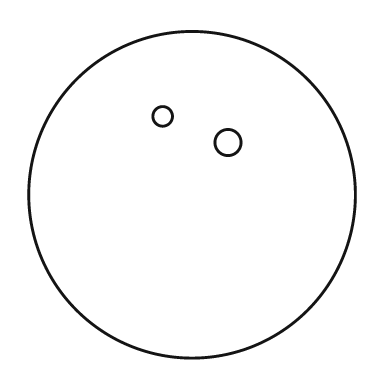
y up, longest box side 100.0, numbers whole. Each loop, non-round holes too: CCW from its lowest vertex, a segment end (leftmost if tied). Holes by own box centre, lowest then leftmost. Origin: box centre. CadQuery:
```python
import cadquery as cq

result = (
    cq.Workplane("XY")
    .moveTo(0.0, 0.0)
    .circle(50.0)
    .moveTo(11.0, 16.0)
    .circle(4.0)
    .moveTo(-9.0, 24.0)
    .circle(3.0)
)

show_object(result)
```